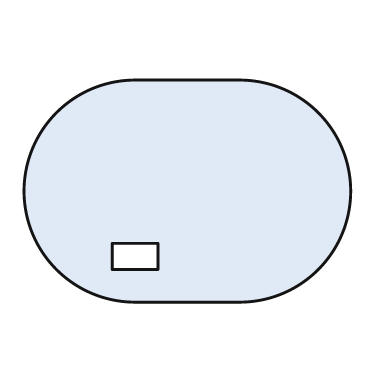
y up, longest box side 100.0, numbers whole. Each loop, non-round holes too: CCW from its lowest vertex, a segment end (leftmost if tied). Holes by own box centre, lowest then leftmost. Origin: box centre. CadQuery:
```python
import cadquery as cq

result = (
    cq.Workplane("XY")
    .moveTo(-16.0, -34.0)
    .lineTo(16.0, -34.0)
    .threePointArc((50.0, 0.0), (16.0, 34.0))
    .lineTo(-16.0, 34.0)
    .threePointArc((-50.0, 0.0), (-16.0, -34.0))
    .close()
    .moveTo(-23.0, -24.0)
    .lineTo(-9.0, -24.0)
    .lineTo(-9.0, -16.0)
    .lineTo(-23.0, -16.0)
    .close()
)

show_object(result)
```